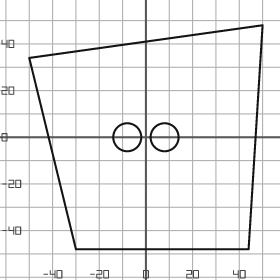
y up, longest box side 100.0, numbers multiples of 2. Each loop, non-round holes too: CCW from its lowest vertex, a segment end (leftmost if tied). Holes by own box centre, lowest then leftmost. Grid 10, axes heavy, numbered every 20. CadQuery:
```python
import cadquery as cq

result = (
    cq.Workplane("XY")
    .moveTo(-30.0, -48.0)
    .lineTo(44.0, -48.0)
    .lineTo(50.0, 48.0)
    .lineTo(-50.0, 34.0)
    .close()
    .moveTo(-8.0, 0.0)
    .circle(6.0)
    .moveTo(8.0, 0.0)
    .circle(6.0)
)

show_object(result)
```